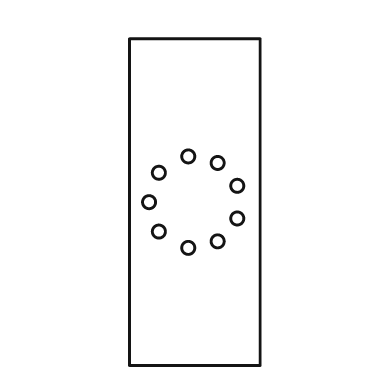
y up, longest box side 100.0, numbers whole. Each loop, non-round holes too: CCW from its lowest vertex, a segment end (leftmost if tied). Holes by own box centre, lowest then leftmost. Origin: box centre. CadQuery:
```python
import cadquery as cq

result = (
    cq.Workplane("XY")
    .moveTo(-20.0, -50.0)
    .lineTo(20.0, -50.0)
    .lineTo(20.0, 50.0)
    .lineTo(-20.0, 50.0)
    .close()
    .moveTo(-2.0, -14.0)
    .circle(2.0)
    .moveTo(7.0, -12.0)
    .circle(2.0)
    .moveTo(-11.0, -9.0)
    .circle(2.0)
    .moveTo(13.0, -5.0)
    .circle(2.0)
    .moveTo(-14.0, 0.0)
    .circle(2.0)
    .moveTo(13.0, 5.0)
    .circle(2.0)
    .moveTo(-11.0, 9.0)
    .circle(2.0)
    .moveTo(7.0, 12.0)
    .circle(2.0)
    .moveTo(-2.0, 14.0)
    .circle(2.0)
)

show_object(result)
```